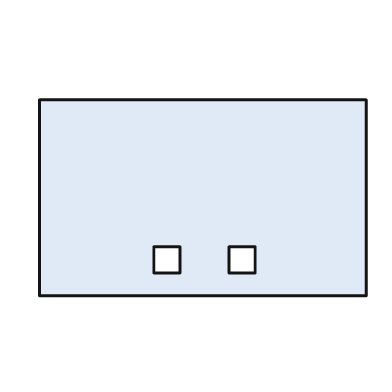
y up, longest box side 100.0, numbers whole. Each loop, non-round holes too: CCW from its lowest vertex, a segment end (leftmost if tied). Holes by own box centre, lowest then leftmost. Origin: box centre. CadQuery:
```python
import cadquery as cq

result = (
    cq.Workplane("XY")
    .moveTo(-50.0, -30.0)
    .lineTo(50.0, -30.0)
    .lineTo(50.0, 30.0)
    .lineTo(-50.0, 30.0)
    .close()
    .moveTo(-15.0, -23.0)
    .lineTo(-7.0, -23.0)
    .lineTo(-7.0, -15.0)
    .lineTo(-15.0, -15.0)
    .close()
    .moveTo(8.0, -23.0)
    .lineTo(16.0, -23.0)
    .lineTo(16.0, -15.0)
    .lineTo(8.0, -15.0)
    .close()
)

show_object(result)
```